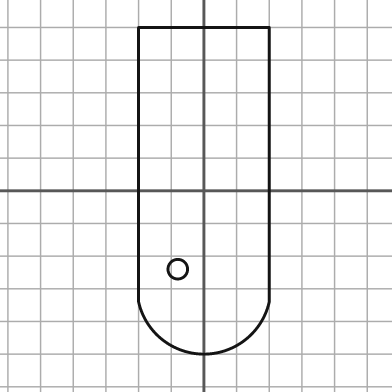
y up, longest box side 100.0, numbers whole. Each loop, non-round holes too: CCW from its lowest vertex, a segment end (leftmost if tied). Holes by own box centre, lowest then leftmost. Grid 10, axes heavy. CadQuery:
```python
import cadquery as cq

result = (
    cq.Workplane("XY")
    .moveTo(-20.0, -34.0)
    .threePointArc((0.0, -50.0), (20.0, -34.0))
    .lineTo(20.0, 50.0)
    .lineTo(-20.0, 50.0)
    .close()
    .moveTo(-8.0, -24.0)
    .circle(3.0)
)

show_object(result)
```